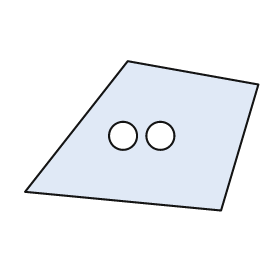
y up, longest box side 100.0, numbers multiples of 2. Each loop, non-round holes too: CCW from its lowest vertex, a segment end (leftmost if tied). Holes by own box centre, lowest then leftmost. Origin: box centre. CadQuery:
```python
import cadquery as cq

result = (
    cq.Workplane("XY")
    .moveTo(34.0, -32.0)
    .lineTo(50.0, 22.0)
    .lineTo(-6.0, 32.0)
    .lineTo(-50.0, -24.0)
    .close()
    .moveTo(-8.0, 0.0)
    .circle(6.0)
    .moveTo(8.0, 0.0)
    .circle(6.0)
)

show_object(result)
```